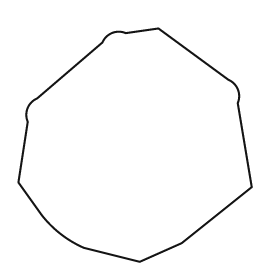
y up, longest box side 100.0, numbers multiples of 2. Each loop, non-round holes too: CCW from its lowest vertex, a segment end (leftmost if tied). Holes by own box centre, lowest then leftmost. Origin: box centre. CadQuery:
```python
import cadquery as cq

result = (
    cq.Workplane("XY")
    .moveTo(2.0, -50.0)
    .lineTo(20.0, -42.0)
    .lineTo(50.0, -18.0)
    .lineTo(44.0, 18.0)
    .threePointArc((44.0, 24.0), (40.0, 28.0))
    .lineTo(10.0, 50.0)
    .lineTo(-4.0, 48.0)
    .threePointArc((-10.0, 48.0), (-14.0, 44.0))
    .lineTo(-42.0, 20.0)
    .threePointArc((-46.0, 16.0), (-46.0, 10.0))
    .lineTo(-50.0, -16.0)
    .lineTo(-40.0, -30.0)
    .threePointArc((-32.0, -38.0), (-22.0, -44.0))
    .close()
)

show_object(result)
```